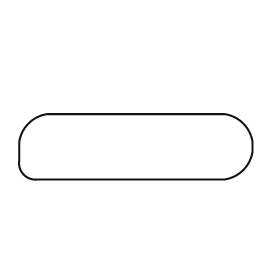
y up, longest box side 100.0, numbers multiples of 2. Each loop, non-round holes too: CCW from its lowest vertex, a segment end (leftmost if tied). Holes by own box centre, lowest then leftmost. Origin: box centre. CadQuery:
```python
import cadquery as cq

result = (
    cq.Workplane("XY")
    .moveTo(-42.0, -14.0)
    .lineTo(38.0, -14.0)
    .threePointArc((46.0, -10.0), (50.0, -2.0))
    .lineTo(50.0, 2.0)
    .threePointArc((46.0, 10.0), (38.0, 14.0))
    .lineTo(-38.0, 14.0)
    .threePointArc((-46.0, 10.0), (-50.0, 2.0))
    .lineTo(-50.0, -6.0)
    .threePointArc((-48.0, -12.0), (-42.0, -14.0))
    .close()
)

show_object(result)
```